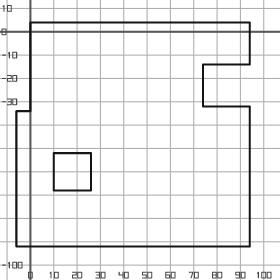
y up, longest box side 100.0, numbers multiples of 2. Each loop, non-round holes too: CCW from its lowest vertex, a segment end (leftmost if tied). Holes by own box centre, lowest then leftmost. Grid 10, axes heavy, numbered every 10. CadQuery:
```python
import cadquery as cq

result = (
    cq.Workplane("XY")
    .moveTo(-6.0, -92.0)
    .lineTo(94.0, -92.0)
    .lineTo(94.0, -32.0)
    .lineTo(74.0, -32.0)
    .lineTo(74.0, -14.0)
    .lineTo(94.0, -14.0)
    .lineTo(94.0, 4.0)
    .lineTo(0.0, 4.0)
    .lineTo(0.0, -34.0)
    .lineTo(-6.0, -34.0)
    .close()
    .moveTo(10.0, -68.0)
    .lineTo(26.0, -68.0)
    .lineTo(26.0, -52.0)
    .lineTo(10.0, -52.0)
    .close()
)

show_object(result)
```